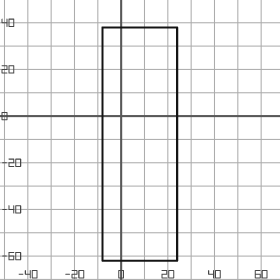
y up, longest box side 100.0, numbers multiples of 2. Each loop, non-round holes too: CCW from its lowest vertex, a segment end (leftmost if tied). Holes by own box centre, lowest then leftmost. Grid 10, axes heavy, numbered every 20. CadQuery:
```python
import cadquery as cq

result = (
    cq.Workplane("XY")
    .moveTo(-8.0, -62.0)
    .lineTo(24.0, -62.0)
    .lineTo(24.0, 38.0)
    .lineTo(-8.0, 38.0)
    .close()
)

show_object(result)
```